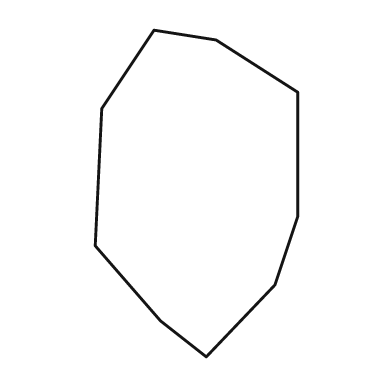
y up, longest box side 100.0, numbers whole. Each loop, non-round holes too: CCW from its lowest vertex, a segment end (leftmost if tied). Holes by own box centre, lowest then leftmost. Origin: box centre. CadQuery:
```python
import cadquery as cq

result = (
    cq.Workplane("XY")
    .moveTo(3.0, -50.0)
    .lineTo(24.0, -28.0)
    .lineTo(31.0, -7.0)
    .lineTo(31.0, 31.0)
    .lineTo(6.0, 47.0)
    .lineTo(-13.0, 50.0)
    .lineTo(-29.0, 26.0)
    .lineTo(-31.0, -16.0)
    .lineTo(-11.0, -39.0)
    .close()
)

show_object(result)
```